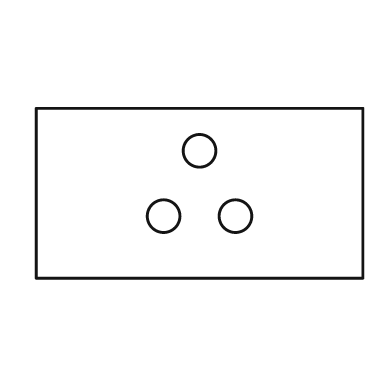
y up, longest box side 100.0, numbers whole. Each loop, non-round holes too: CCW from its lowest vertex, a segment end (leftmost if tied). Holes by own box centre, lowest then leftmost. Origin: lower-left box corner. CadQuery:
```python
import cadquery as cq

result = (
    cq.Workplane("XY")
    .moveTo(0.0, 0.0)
    .lineTo(100.0, 0.0)
    .lineTo(100.0, 52.0)
    .lineTo(0.0, 52.0)
    .close()
    .moveTo(39.0, 19.0)
    .circle(5.0)
    .moveTo(61.0, 19.0)
    .circle(5.0)
    .moveTo(50.0, 39.0)
    .circle(5.0)
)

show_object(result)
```